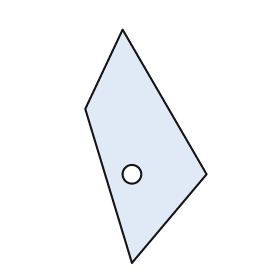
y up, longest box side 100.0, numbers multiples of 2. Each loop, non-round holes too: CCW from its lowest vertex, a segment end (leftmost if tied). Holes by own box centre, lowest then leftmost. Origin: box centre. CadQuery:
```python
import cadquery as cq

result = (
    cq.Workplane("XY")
    .moveTo(-6.0, -50.0)
    .lineTo(26.0, -12.0)
    .lineTo(-10.0, 50.0)
    .lineTo(-26.0, 16.0)
    .close()
    .moveTo(-6.0, -12.0)
    .circle(4.0)
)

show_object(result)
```